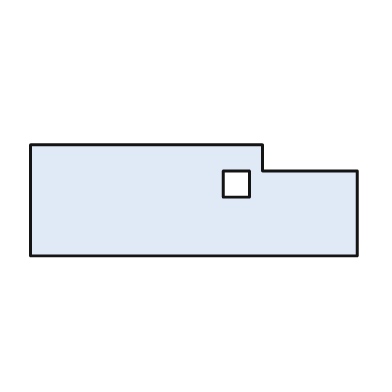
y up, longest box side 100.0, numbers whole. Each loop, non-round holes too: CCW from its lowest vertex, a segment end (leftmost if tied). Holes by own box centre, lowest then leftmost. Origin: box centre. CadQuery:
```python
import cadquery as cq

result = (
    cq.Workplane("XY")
    .moveTo(-50.0, -17.0)
    .lineTo(50.0, -17.0)
    .lineTo(50.0, 9.0)
    .lineTo(21.0, 9.0)
    .lineTo(21.0, 17.0)
    .lineTo(-50.0, 17.0)
    .close()
    .moveTo(9.0, 1.0)
    .lineTo(17.0, 1.0)
    .lineTo(17.0, 9.0)
    .lineTo(9.0, 9.0)
    .close()
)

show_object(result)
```